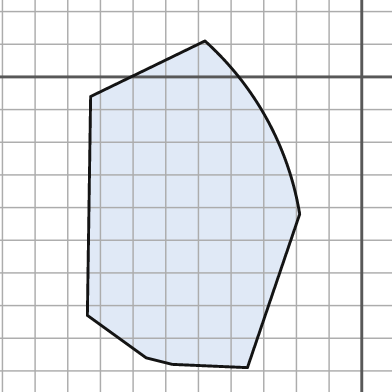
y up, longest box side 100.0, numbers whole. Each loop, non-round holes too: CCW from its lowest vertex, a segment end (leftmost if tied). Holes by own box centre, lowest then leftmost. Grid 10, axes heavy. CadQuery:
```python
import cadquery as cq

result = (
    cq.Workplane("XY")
    .moveTo(-35.0, -89.0)
    .lineTo(-19.0, -42.0)
    .threePointArc((-29.0, -13.0), (-48.0, 11.0))
    .lineTo(-83.0, -6.0)
    .lineTo(-84.0, -73.0)
    .lineTo(-66.0, -86.0)
    .lineTo(-58.0, -88.0)
    .close()
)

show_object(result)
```